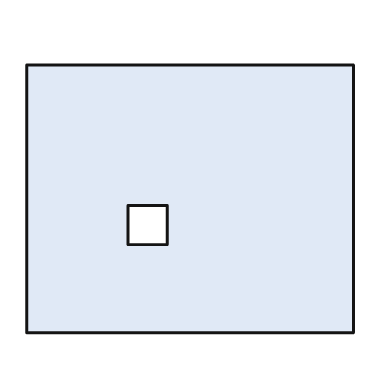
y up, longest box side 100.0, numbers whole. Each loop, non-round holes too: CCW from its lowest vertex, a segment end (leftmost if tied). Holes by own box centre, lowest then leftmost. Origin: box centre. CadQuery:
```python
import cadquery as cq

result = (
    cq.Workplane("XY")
    .moveTo(-50.0, -41.0)
    .lineTo(50.0, -41.0)
    .lineTo(50.0, 41.0)
    .lineTo(-50.0, 41.0)
    .close()
    .moveTo(-19.0, -14.0)
    .lineTo(-7.0, -14.0)
    .lineTo(-7.0, -2.0)
    .lineTo(-19.0, -2.0)
    .close()
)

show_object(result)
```